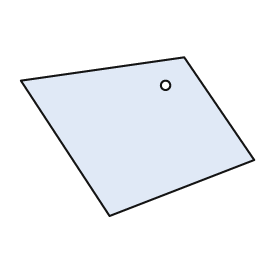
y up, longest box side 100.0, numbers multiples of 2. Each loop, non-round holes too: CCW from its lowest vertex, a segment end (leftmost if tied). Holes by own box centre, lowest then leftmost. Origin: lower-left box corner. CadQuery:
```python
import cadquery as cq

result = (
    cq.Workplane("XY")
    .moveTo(38.0, 0.0)
    .lineTo(100.0, 24.0)
    .lineTo(70.0, 68.0)
    .lineTo(0.0, 58.0)
    .close()
    .moveTo(62.0, 56.0)
    .circle(2.0)
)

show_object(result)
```